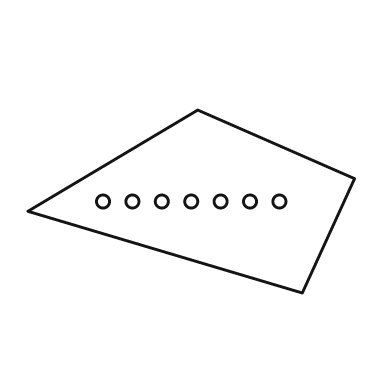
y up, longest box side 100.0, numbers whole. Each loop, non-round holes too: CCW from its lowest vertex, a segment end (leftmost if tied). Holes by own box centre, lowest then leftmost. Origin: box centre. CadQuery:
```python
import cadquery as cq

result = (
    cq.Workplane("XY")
    .moveTo(34.0, -28.0)
    .lineTo(50.0, 7.0)
    .lineTo(2.0, 28.0)
    .lineTo(-50.0, -3.0)
    .close()
    .moveTo(-27.0, 0.0)
    .circle(2.0)
    .moveTo(-18.0, 0.0)
    .circle(2.0)
    .moveTo(-9.0, 0.0)
    .circle(2.0)
    .moveTo(0.0, 0.0)
    .circle(2.0)
    .moveTo(9.0, 0.0)
    .circle(2.0)
    .moveTo(18.0, 0.0)
    .circle(2.0)
    .moveTo(27.0, 0.0)
    .circle(2.0)
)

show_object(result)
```